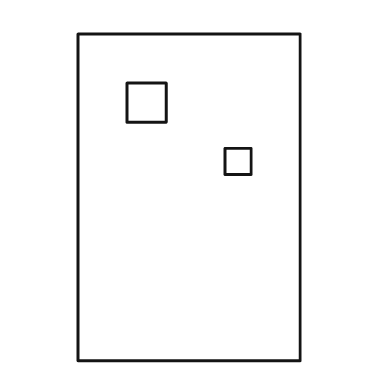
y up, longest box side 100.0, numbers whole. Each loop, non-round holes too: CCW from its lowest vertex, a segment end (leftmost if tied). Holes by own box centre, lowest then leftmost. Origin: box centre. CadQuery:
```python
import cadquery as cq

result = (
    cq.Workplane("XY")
    .moveTo(-34.0, -50.0)
    .lineTo(34.0, -50.0)
    .lineTo(34.0, 50.0)
    .lineTo(-34.0, 50.0)
    .close()
    .moveTo(11.0, 7.0)
    .lineTo(19.0, 7.0)
    .lineTo(19.0, 15.0)
    .lineTo(11.0, 15.0)
    .close()
    .moveTo(-19.0, 23.0)
    .lineTo(-7.0, 23.0)
    .lineTo(-7.0, 35.0)
    .lineTo(-19.0, 35.0)
    .close()
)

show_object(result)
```